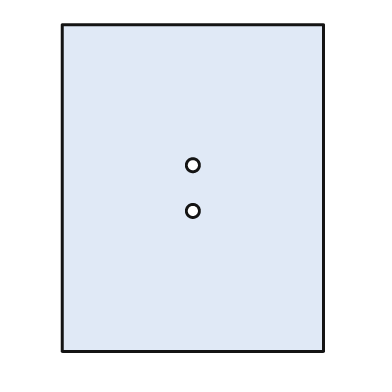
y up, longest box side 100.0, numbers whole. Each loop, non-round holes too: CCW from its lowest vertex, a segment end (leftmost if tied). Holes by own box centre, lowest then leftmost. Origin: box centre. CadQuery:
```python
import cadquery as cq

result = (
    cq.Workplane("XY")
    .moveTo(-40.0, -50.0)
    .lineTo(40.0, -50.0)
    .lineTo(40.0, 50.0)
    .lineTo(-40.0, 50.0)
    .close()
    .moveTo(0.0, -7.0)
    .circle(2.0)
    .moveTo(0.0, 7.0)
    .circle(2.0)
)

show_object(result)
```